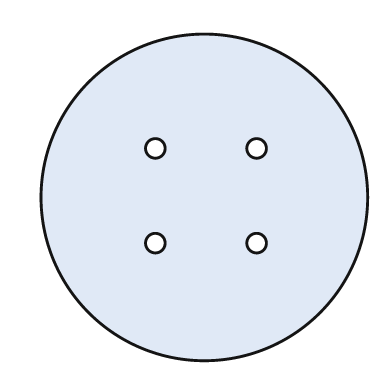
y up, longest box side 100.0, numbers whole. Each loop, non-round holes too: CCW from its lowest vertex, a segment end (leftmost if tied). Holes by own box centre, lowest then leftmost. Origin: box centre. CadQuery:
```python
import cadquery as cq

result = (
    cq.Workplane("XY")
    .moveTo(0.0, 0.0)
    .circle(50.0)
    .moveTo(-15.0, -14.0)
    .circle(3.0)
    .moveTo(16.0, -14.0)
    .circle(3.0)
    .moveTo(-15.0, 15.0)
    .circle(3.0)
    .moveTo(16.0, 15.0)
    .circle(3.0)
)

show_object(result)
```